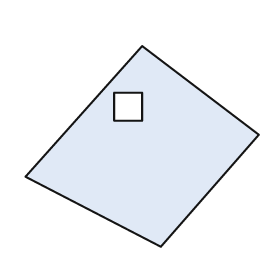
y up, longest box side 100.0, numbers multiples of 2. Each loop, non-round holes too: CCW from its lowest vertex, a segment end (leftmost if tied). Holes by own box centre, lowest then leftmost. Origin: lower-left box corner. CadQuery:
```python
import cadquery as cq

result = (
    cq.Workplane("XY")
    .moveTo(58.0, 0.0)
    .lineTo(100.0, 48.0)
    .lineTo(50.0, 86.0)
    .lineTo(0.0, 30.0)
    .close()
    .moveTo(38.0, 54.0)
    .lineTo(50.0, 54.0)
    .lineTo(50.0, 66.0)
    .lineTo(38.0, 66.0)
    .close()
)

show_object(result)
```